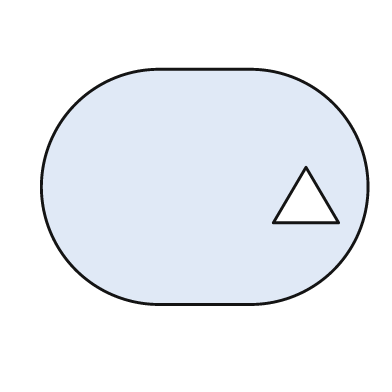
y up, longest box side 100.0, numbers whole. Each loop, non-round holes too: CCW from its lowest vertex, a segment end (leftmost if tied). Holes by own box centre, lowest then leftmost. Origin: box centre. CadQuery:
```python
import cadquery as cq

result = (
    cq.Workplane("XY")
    .moveTo(-14.0, -36.0)
    .lineTo(14.0, -36.0)
    .threePointArc((50.0, 0.0), (14.0, 36.0))
    .lineTo(-14.0, 36.0)
    .threePointArc((-50.0, 0.0), (-14.0, -36.0))
    .close()
    .moveTo(21.0, -11.0)
    .lineTo(41.0, -11.0)
    .lineTo(31.0, 6.0)
    .close()
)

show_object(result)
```